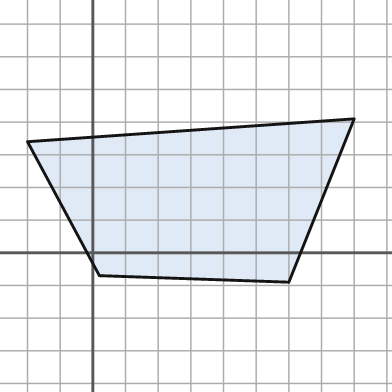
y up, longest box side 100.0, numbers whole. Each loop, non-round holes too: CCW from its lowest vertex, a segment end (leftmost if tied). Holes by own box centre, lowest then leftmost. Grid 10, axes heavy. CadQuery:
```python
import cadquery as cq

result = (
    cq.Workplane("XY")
    .moveTo(60.0, -9.0)
    .lineTo(80.0, 41.0)
    .lineTo(-20.0, 34.0)
    .lineTo(2.0, -7.0)
    .close()
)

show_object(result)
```